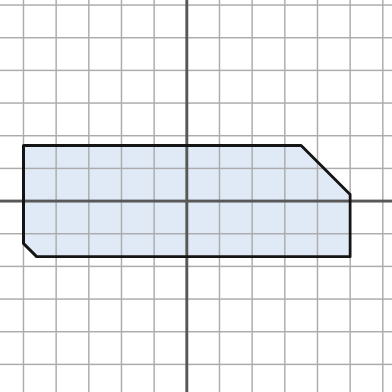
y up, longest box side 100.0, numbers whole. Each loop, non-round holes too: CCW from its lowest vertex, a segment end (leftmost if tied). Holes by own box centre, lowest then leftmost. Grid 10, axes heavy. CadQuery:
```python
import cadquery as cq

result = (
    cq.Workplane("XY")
    .moveTo(-46.0, -17.0)
    .lineTo(50.0, -17.0)
    .lineTo(50.0, 2.0)
    .lineTo(35.0, 17.0)
    .lineTo(-50.0, 17.0)
    .lineTo(-50.0, -13.0)
    .close()
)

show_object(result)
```